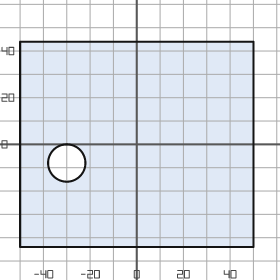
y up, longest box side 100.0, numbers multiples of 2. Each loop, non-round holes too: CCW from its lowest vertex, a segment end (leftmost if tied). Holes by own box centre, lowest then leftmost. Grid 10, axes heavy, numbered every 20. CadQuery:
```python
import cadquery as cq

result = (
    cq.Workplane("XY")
    .moveTo(-50.0, -44.0)
    .lineTo(50.0, -44.0)
    .lineTo(50.0, 44.0)
    .lineTo(-50.0, 44.0)
    .close()
    .moveTo(-30.0, -8.0)
    .circle(8.0)
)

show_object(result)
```